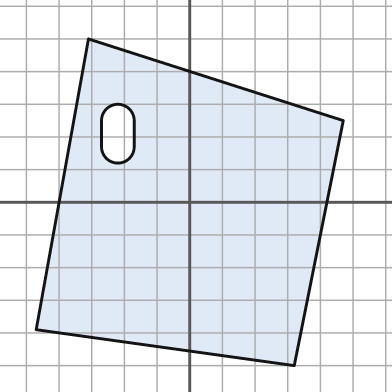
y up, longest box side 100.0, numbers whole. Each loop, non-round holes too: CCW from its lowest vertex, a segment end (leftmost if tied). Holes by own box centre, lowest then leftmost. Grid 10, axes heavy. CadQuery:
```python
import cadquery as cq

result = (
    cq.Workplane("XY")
    .moveTo(32.0, -50.0)
    .lineTo(47.0, 25.0)
    .lineTo(-31.0, 50.0)
    .lineTo(-47.0, -39.0)
    .close()
    .moveTo(-27.0, 17.0)
    .threePointArc((-22.0, 12.0), (-17.0, 17.0))
    .lineTo(-17.0, 25.0)
    .threePointArc((-22.0, 30.0), (-27.0, 25.0))
    .close()
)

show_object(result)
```